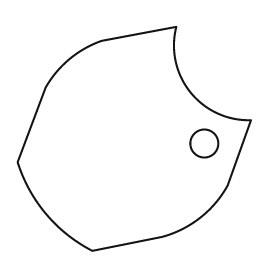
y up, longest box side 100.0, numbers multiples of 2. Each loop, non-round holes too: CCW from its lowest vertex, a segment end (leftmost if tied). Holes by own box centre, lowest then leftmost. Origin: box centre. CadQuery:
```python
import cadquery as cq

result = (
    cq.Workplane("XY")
    .moveTo(-18.0, -48.0)
    .lineTo(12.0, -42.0)
    .threePointArc((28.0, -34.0), (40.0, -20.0))
    .lineTo(50.0, 8.0)
    .threePointArc((24.0, 20.0), (18.0, 48.0))
    .lineTo(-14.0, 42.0)
    .threePointArc((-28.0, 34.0), (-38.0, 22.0))
    .lineTo(-50.0, -10.0)
    .threePointArc((-38.0, -32.0), (-18.0, -48.0))
    .close()
    .moveTo(30.0, -2.0)
    .circle(6.0)
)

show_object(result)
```